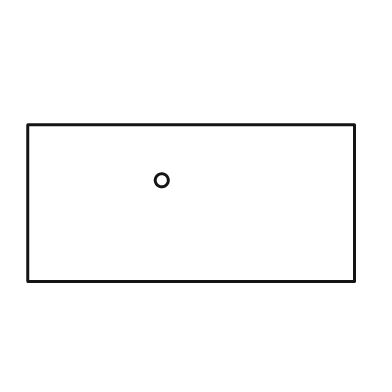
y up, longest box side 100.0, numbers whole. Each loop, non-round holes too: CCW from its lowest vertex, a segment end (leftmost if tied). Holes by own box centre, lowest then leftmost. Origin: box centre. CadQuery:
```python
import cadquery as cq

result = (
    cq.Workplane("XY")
    .moveTo(-50.0, -24.0)
    .lineTo(50.0, -24.0)
    .lineTo(50.0, 24.0)
    .lineTo(-50.0, 24.0)
    .close()
    .moveTo(-9.0, 7.0)
    .circle(2.0)
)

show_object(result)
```